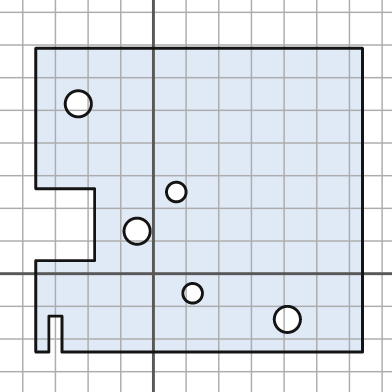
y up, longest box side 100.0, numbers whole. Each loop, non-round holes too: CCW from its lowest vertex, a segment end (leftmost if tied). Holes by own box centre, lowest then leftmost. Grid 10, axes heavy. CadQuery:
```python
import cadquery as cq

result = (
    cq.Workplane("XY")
    .moveTo(-36.0, -24.0)
    .lineTo(-32.0, -24.0)
    .lineTo(-32.0, -13.0)
    .lineTo(-28.0, -13.0)
    .lineTo(-28.0, -24.0)
    .lineTo(64.0, -24.0)
    .lineTo(64.0, 69.0)
    .lineTo(-36.0, 69.0)
    .lineTo(-36.0, 26.0)
    .lineTo(-18.0, 26.0)
    .lineTo(-18.0, 4.0)
    .lineTo(-36.0, 4.0)
    .close()
    .moveTo(41.0, -14.0)
    .circle(4.0)
    .moveTo(12.0, -6.0)
    .circle(3.0)
    .moveTo(-5.0, 13.0)
    .circle(4.0)
    .moveTo(7.0, 25.0)
    .circle(3.0)
    .moveTo(-23.0, 52.0)
    .circle(4.0)
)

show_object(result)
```